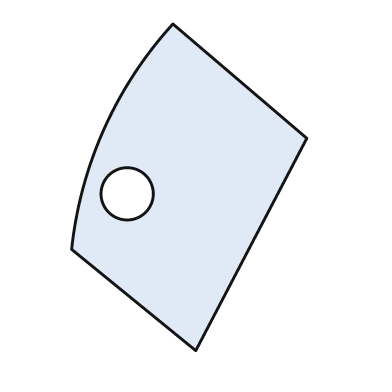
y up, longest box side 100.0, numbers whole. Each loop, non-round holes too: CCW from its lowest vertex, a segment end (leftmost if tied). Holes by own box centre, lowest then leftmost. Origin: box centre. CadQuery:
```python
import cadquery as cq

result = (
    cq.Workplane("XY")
    .moveTo(2.0, -50.0)
    .lineTo(36.0, 15.0)
    .lineTo(-5.0, 50.0)
    .threePointArc((-26.0, 18.0), (-36.0, -19.0))
    .close()
    .moveTo(-19.0, -2.0)
    .circle(8.0)
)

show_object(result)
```